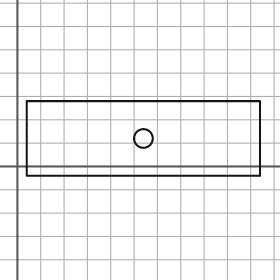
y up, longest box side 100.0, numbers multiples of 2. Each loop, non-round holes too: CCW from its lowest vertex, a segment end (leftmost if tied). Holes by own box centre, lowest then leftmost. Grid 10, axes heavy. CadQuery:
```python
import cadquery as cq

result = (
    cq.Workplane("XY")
    .moveTo(4.0, -4.0)
    .lineTo(104.0, -4.0)
    .lineTo(104.0, 28.0)
    .lineTo(4.0, 28.0)
    .close()
    .moveTo(54.0, 12.0)
    .circle(4.0)
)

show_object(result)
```